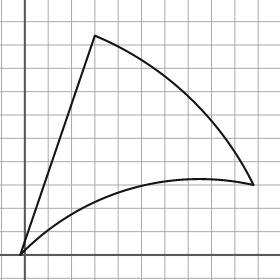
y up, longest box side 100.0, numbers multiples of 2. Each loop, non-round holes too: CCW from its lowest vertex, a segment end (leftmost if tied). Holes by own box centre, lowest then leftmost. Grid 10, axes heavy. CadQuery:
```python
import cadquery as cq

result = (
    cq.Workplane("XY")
    .moveTo(-2.0, 0.0)
    .threePointArc((44.0, 28.0), (98.0, 30.0))
    .threePointArc((70.0, 68.0), (30.0, 94.0))
    .close()
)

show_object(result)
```